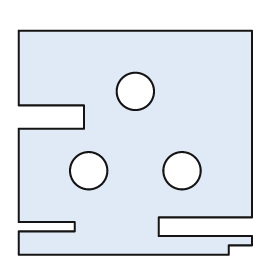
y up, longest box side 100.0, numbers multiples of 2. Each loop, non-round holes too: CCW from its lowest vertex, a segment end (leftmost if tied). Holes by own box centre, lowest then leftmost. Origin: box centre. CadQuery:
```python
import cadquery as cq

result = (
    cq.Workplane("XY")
    .moveTo(-50.0, -48.0)
    .lineTo(40.0, -48.0)
    .lineTo(40.0, -44.0)
    .lineTo(50.0, -44.0)
    .lineTo(50.0, -40.0)
    .lineTo(10.0, -40.0)
    .lineTo(10.0, -32.0)
    .lineTo(50.0, -32.0)
    .lineTo(50.0, 48.0)
    .lineTo(-50.0, 48.0)
    .lineTo(-50.0, 16.0)
    .lineTo(-22.0, 16.0)
    .lineTo(-22.0, 6.0)
    .lineTo(-50.0, 6.0)
    .lineTo(-50.0, -34.0)
    .lineTo(-26.0, -34.0)
    .lineTo(-26.0, -38.0)
    .lineTo(-50.0, -38.0)
    .close()
    .moveTo(-20.0, -12.0)
    .circle(8.0)
    .moveTo(20.0, -12.0)
    .circle(8.0)
    .moveTo(0.0, 22.0)
    .circle(8.0)
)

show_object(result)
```